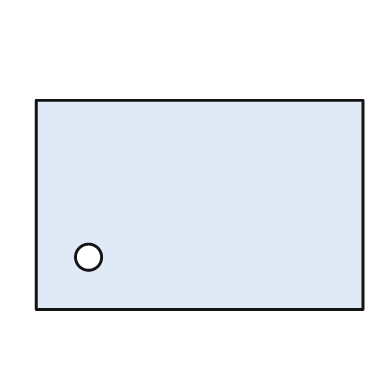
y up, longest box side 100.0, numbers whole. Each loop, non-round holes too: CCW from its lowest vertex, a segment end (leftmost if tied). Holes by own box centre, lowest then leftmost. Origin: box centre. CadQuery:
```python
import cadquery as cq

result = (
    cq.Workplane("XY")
    .moveTo(-50.0, -32.0)
    .lineTo(50.0, -32.0)
    .lineTo(50.0, 32.0)
    .lineTo(-50.0, 32.0)
    .close()
    .moveTo(-34.0, -16.0)
    .circle(4.0)
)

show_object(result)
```